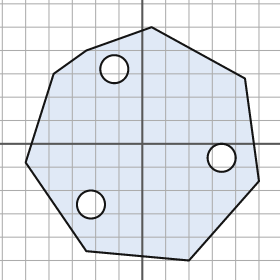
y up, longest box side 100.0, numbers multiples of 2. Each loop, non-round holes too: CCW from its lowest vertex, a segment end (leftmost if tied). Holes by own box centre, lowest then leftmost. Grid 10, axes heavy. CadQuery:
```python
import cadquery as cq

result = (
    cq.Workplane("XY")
    .moveTo(20.0, -50.0)
    .lineTo(50.0, -16.0)
    .lineTo(44.0, 28.0)
    .lineTo(4.0, 50.0)
    .lineTo(-24.0, 40.0)
    .lineTo(-38.0, 30.0)
    .lineTo(-50.0, -8.0)
    .lineTo(-24.0, -46.0)
    .close()
    .moveTo(-22.0, -26.0)
    .circle(6.0)
    .moveTo(34.0, -6.0)
    .circle(6.0)
    .moveTo(-12.0, 32.0)
    .circle(6.0)
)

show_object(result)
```